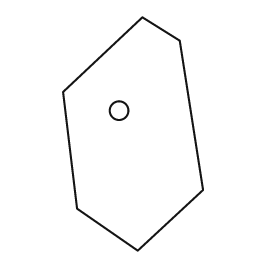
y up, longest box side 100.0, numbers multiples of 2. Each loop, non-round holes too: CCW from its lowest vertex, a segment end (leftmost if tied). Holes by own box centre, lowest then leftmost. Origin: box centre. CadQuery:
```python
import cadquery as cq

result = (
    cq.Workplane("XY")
    .moveTo(2.0, -50.0)
    .lineTo(30.0, -24.0)
    .lineTo(20.0, 40.0)
    .lineTo(4.0, 50.0)
    .lineTo(-30.0, 18.0)
    .lineTo(-24.0, -32.0)
    .close()
    .moveTo(-6.0, 10.0)
    .circle(4.0)
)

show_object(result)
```